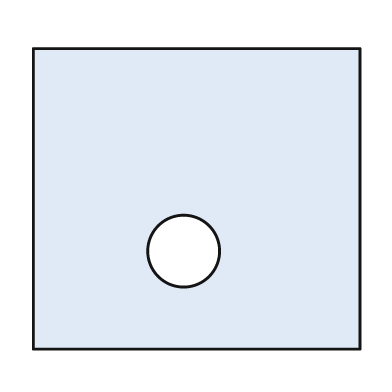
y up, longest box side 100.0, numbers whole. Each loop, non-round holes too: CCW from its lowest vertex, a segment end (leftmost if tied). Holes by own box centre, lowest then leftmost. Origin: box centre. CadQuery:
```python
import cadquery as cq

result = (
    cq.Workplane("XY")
    .moveTo(-50.0, -46.0)
    .lineTo(50.0, -46.0)
    .lineTo(50.0, 46.0)
    .lineTo(-50.0, 46.0)
    .close()
    .moveTo(-4.0, -16.0)
    .circle(11.0)
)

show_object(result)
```